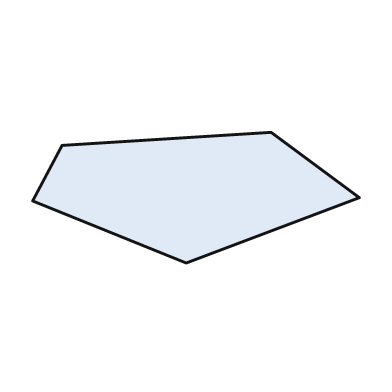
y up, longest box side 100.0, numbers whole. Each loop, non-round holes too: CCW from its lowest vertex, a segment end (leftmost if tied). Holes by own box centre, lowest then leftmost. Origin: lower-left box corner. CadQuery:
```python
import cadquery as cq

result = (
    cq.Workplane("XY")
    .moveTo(47.0, 0.0)
    .lineTo(100.0, 20.0)
    .lineTo(73.0, 40.0)
    .lineTo(9.0, 36.0)
    .lineTo(0.0, 19.0)
    .close()
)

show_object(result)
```